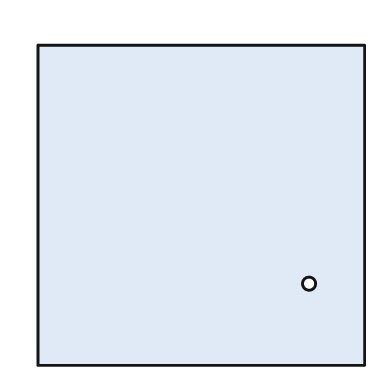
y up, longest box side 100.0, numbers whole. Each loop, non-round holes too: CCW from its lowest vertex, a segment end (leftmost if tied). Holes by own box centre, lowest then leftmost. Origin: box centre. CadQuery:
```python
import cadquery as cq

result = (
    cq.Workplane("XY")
    .moveTo(-50.0, -49.0)
    .lineTo(50.0, -49.0)
    .lineTo(50.0, 49.0)
    .lineTo(-50.0, 49.0)
    .close()
    .moveTo(33.0, -24.0)
    .circle(2.0)
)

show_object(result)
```